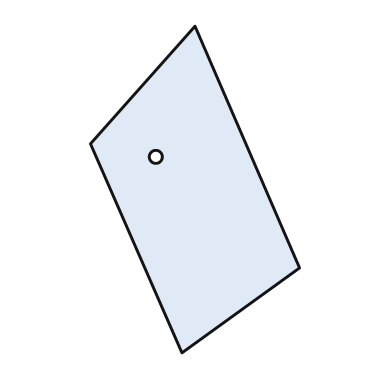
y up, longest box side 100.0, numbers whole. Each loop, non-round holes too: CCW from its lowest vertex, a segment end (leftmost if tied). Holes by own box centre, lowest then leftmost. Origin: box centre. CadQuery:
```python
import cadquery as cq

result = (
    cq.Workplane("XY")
    .moveTo(-4.0, -50.0)
    .lineTo(32.0, -24.0)
    .lineTo(0.0, 50.0)
    .lineTo(-32.0, 14.0)
    .close()
    .moveTo(-12.0, 10.0)
    .circle(2.0)
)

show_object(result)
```